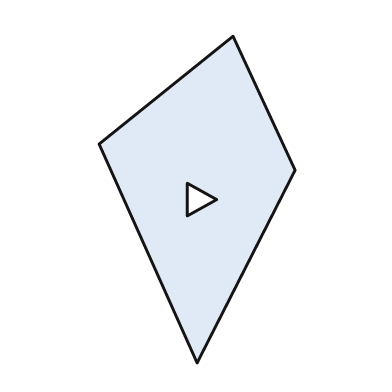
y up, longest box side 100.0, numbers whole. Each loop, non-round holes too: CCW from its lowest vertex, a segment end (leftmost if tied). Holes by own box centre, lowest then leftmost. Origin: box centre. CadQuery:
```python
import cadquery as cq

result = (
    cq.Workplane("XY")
    .moveTo(0.0, -50.0)
    .lineTo(30.0, 9.0)
    .lineTo(11.0, 50.0)
    .lineTo(-30.0, 17.0)
    .close()
    .moveTo(-3.0, -5.0)
    .lineTo(6.0, 0.0)
    .lineTo(-3.0, 5.0)
    .close()
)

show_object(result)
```